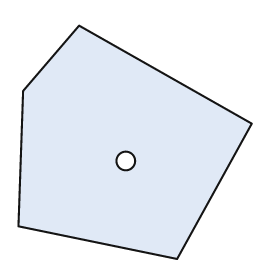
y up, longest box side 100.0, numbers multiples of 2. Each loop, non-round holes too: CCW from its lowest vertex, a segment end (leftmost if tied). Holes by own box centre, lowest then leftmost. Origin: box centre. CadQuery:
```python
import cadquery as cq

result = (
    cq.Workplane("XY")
    .moveTo(18.0, -50.0)
    .lineTo(50.0, 8.0)
    .lineTo(-24.0, 50.0)
    .lineTo(-48.0, 22.0)
    .lineTo(-50.0, -36.0)
    .close()
    .moveTo(-4.0, -8.0)
    .circle(4.0)
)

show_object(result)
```